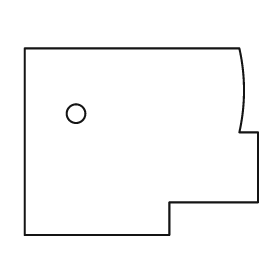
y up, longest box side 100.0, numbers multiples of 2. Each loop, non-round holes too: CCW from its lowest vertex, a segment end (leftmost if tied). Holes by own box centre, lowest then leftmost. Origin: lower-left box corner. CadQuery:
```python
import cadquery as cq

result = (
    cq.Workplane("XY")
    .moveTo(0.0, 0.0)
    .lineTo(62.0, 0.0)
    .lineTo(62.0, 14.0)
    .lineTo(100.0, 14.0)
    .lineTo(100.0, 44.0)
    .lineTo(92.0, 44.0)
    .threePointArc((94.0, 62.0), (92.0, 80.0))
    .lineTo(0.0, 80.0)
    .close()
    .moveTo(22.0, 52.0)
    .circle(4.0)
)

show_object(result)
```